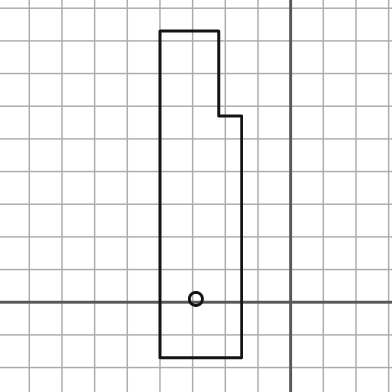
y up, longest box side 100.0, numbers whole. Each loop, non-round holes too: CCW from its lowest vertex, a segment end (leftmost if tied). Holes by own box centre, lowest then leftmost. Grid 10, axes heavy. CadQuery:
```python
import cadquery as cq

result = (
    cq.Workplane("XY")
    .moveTo(-40.0, -17.0)
    .lineTo(-15.0, -17.0)
    .lineTo(-15.0, 57.0)
    .lineTo(-22.0, 57.0)
    .lineTo(-22.0, 83.0)
    .lineTo(-40.0, 83.0)
    .close()
    .moveTo(-29.0, 1.0)
    .circle(2.0)
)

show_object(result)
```